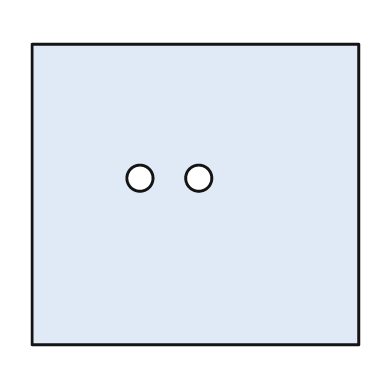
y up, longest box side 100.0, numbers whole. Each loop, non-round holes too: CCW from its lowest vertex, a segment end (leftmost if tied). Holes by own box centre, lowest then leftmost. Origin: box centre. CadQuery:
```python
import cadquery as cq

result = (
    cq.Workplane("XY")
    .moveTo(-50.0, -46.0)
    .lineTo(50.0, -46.0)
    .lineTo(50.0, 46.0)
    .lineTo(-50.0, 46.0)
    .close()
    .moveTo(-17.0, 5.0)
    .circle(4.0)
    .moveTo(1.0, 5.0)
    .circle(4.0)
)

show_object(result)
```